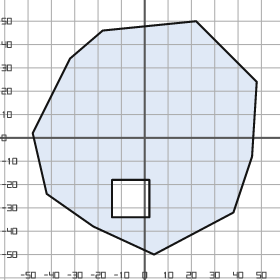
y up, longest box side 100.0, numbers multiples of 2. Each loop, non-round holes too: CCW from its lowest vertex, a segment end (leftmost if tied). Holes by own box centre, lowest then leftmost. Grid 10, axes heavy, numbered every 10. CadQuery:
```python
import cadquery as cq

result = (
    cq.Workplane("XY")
    .moveTo(4.0, -50.0)
    .lineTo(38.0, -32.0)
    .lineTo(46.0, -8.0)
    .lineTo(48.0, 24.0)
    .lineTo(22.0, 50.0)
    .lineTo(-18.0, 46.0)
    .lineTo(-32.0, 34.0)
    .lineTo(-48.0, 2.0)
    .lineTo(-42.0, -24.0)
    .lineTo(-22.0, -38.0)
    .close()
    .moveTo(-14.0, -34.0)
    .lineTo(2.0, -34.0)
    .lineTo(2.0, -18.0)
    .lineTo(-14.0, -18.0)
    .close()
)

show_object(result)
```